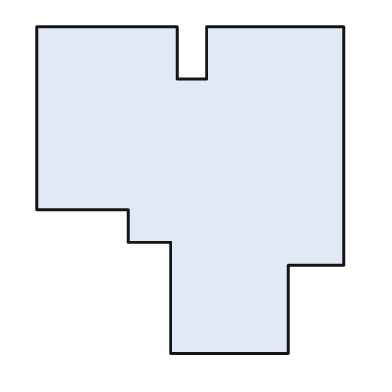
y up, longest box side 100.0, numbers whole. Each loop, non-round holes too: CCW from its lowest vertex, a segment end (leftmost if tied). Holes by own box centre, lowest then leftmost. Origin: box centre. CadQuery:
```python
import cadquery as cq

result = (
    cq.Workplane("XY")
    .moveTo(-6.0, -50.0)
    .lineTo(30.0, -50.0)
    .lineTo(30.0, -23.0)
    .lineTo(47.0, -23.0)
    .lineTo(47.0, 50.0)
    .lineTo(5.0, 50.0)
    .lineTo(5.0, 34.0)
    .lineTo(-4.0, 34.0)
    .lineTo(-4.0, 50.0)
    .lineTo(-47.0, 50.0)
    .lineTo(-47.0, -6.0)
    .lineTo(-19.0, -6.0)
    .lineTo(-19.0, -16.0)
    .lineTo(-6.0, -16.0)
    .close()
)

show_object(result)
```